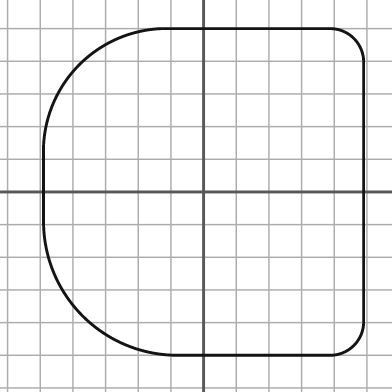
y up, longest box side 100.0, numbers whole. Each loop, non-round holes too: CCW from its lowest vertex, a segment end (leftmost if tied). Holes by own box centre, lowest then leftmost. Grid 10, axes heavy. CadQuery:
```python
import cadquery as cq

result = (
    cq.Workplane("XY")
    .moveTo(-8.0, -50.0)
    .lineTo(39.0, -50.0)
    .threePointArc((46.0, -47.0), (49.0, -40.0))
    .lineTo(49.0, 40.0)
    .threePointArc((46.0, 47.0), (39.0, 50.0))
    .lineTo(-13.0, 50.0)
    .threePointArc((-38.0, 39.0), (-49.0, 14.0))
    .lineTo(-49.0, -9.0)
    .threePointArc((-37.0, -38.0), (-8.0, -50.0))
    .close()
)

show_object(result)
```